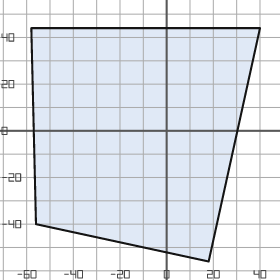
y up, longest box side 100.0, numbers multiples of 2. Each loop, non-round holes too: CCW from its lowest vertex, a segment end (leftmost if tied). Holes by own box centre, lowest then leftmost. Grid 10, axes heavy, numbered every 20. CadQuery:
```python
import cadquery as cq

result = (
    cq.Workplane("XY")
    .moveTo(18.0, -56.0)
    .lineTo(40.0, 44.0)
    .lineTo(-58.0, 44.0)
    .lineTo(-56.0, -40.0)
    .close()
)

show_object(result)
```